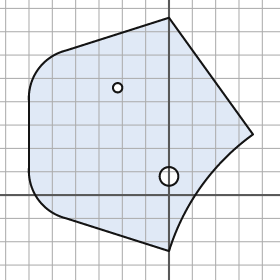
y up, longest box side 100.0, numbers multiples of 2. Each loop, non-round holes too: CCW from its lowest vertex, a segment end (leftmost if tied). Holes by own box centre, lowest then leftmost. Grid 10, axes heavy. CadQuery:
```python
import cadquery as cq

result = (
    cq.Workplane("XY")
    .moveTo(0.0, -24.0)
    .threePointArc((14.0, 4.0), (36.0, 26.0))
    .lineTo(0.0, 76.0)
    .lineTo(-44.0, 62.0)
    .threePointArc((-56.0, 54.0), (-60.0, 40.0))
    .lineTo(-60.0, 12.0)
    .threePointArc((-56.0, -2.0), (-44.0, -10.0))
    .close()
    .moveTo(0.0, 8.0)
    .circle(4.0)
    .moveTo(-22.0, 46.0)
    .circle(2.0)
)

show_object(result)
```